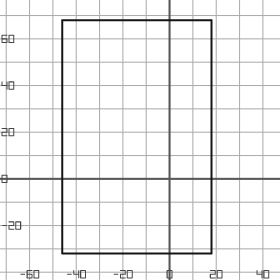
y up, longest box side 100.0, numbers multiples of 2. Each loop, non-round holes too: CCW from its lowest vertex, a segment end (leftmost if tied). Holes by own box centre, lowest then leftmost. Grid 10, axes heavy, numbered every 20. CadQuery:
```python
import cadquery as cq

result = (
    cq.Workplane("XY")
    .moveTo(-46.0, -32.0)
    .lineTo(18.0, -32.0)
    .lineTo(18.0, 68.0)
    .lineTo(-46.0, 68.0)
    .close()
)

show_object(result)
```